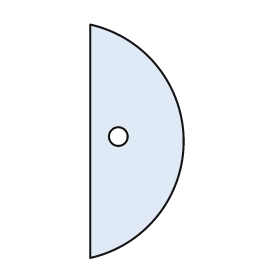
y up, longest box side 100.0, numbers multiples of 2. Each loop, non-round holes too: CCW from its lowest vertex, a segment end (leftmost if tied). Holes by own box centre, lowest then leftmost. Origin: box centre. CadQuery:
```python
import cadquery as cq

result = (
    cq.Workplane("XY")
    .moveTo(-20.0, -50.0)
    .threePointArc((20.0, 0.0), (-20.0, 50.0))
    .close()
    .moveTo(-8.0, 2.0)
    .circle(4.0)
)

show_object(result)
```